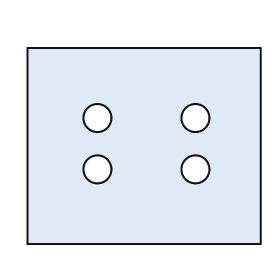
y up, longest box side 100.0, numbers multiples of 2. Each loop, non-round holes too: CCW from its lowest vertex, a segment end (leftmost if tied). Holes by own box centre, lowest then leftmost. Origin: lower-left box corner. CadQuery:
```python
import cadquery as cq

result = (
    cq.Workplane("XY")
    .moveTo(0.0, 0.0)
    .lineTo(100.0, 0.0)
    .lineTo(100.0, 84.0)
    .lineTo(0.0, 84.0)
    .close()
    .moveTo(30.0, 32.0)
    .circle(6.0)
    .moveTo(72.0, 32.0)
    .circle(6.0)
    .moveTo(30.0, 54.0)
    .circle(6.0)
    .moveTo(72.0, 54.0)
    .circle(6.0)
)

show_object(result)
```